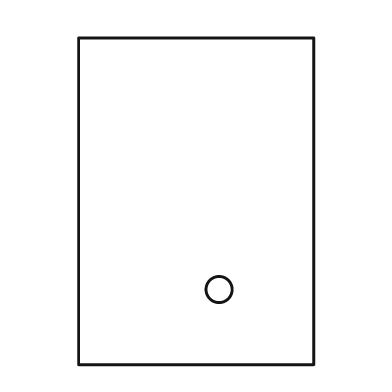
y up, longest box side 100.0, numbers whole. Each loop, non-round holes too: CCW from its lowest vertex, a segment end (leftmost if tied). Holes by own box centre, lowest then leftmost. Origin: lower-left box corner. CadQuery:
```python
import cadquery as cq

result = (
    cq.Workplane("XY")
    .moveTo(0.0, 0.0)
    .lineTo(72.0, 0.0)
    .lineTo(72.0, 100.0)
    .lineTo(0.0, 100.0)
    .close()
    .moveTo(43.0, 23.0)
    .circle(4.0)
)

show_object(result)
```